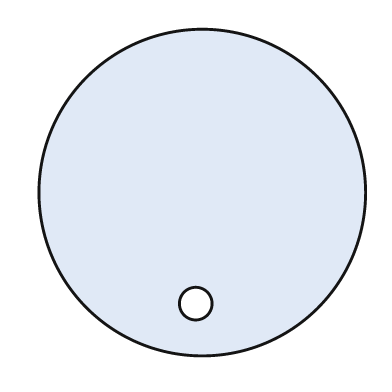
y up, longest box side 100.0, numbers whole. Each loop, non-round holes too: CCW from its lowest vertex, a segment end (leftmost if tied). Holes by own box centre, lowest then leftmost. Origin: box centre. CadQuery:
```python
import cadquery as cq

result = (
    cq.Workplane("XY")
    .moveTo(0.0, 0.0)
    .circle(50.0)
    .moveTo(-2.0, -34.0)
    .circle(5.0)
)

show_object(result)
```